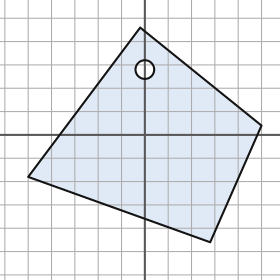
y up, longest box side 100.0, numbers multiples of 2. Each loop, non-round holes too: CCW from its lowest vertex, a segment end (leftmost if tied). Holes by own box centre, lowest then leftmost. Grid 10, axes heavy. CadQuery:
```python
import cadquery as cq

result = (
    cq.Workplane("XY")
    .moveTo(28.0, -46.0)
    .lineTo(50.0, 4.0)
    .lineTo(-2.0, 46.0)
    .lineTo(-50.0, -18.0)
    .close()
    .moveTo(0.0, 28.0)
    .circle(4.0)
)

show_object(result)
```